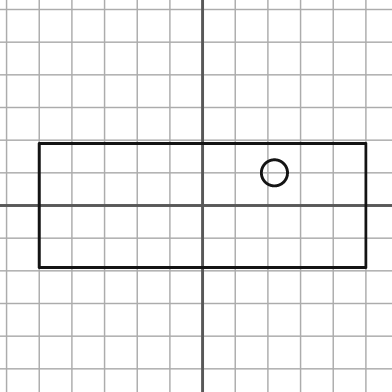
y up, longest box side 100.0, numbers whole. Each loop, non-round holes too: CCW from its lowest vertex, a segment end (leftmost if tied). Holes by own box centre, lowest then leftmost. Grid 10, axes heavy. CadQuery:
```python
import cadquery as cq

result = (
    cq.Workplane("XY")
    .moveTo(-50.0, -19.0)
    .lineTo(50.0, -19.0)
    .lineTo(50.0, 19.0)
    .lineTo(-50.0, 19.0)
    .close()
    .moveTo(22.0, 10.0)
    .circle(4.0)
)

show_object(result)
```